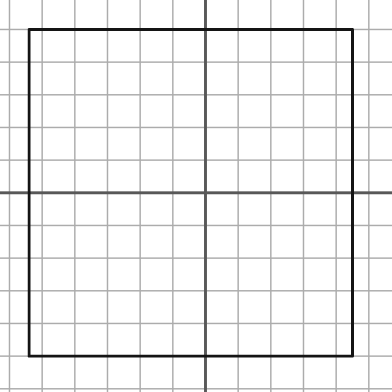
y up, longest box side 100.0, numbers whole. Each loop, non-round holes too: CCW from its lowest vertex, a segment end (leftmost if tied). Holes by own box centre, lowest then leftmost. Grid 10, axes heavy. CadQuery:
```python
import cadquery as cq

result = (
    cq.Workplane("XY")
    .moveTo(-54.0, -50.0)
    .lineTo(45.0, -50.0)
    .lineTo(45.0, 50.0)
    .lineTo(-54.0, 50.0)
    .close()
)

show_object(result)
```